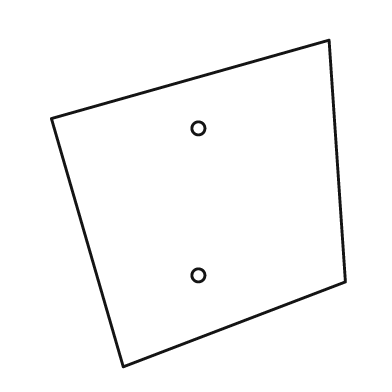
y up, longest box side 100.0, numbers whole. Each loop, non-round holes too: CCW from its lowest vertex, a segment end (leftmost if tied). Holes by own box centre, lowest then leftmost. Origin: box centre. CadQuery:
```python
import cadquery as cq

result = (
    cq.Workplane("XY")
    .moveTo(-23.0, -50.0)
    .lineTo(45.0, -24.0)
    .lineTo(40.0, 50.0)
    .lineTo(-45.0, 26.0)
    .close()
    .moveTo(0.0, -22.0)
    .circle(2.0)
    .moveTo(0.0, 23.0)
    .circle(2.0)
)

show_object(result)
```